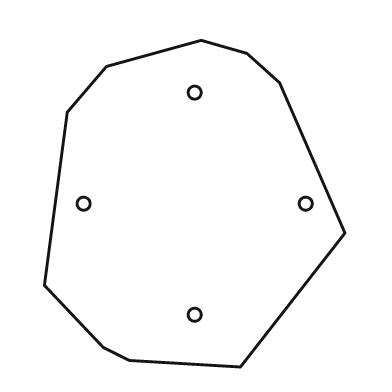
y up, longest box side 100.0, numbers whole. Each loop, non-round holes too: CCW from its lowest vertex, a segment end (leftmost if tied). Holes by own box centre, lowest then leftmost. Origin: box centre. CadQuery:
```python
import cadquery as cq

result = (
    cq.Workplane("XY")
    .moveTo(14.0, -50.0)
    .lineTo(46.0, -9.0)
    .lineTo(26.0, 37.0)
    .lineTo(16.0, 46.0)
    .lineTo(2.0, 50.0)
    .lineTo(-27.0, 42.0)
    .lineTo(-39.0, 28.0)
    .lineTo(-46.0, -25.0)
    .lineTo(-28.0, -44.0)
    .lineTo(-20.0, -48.0)
    .close()
    .moveTo(0.0, -34.0)
    .circle(2.0)
    .moveTo(-34.0, 0.0)
    .circle(2.0)
    .moveTo(34.0, 0.0)
    .circle(2.0)
    .moveTo(0.0, 34.0)
    .circle(2.0)
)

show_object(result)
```